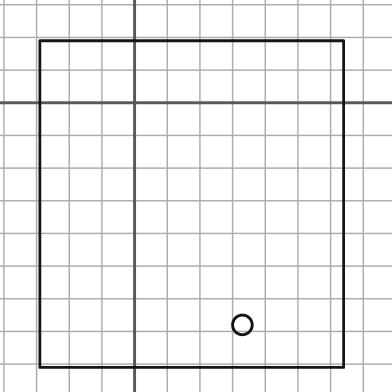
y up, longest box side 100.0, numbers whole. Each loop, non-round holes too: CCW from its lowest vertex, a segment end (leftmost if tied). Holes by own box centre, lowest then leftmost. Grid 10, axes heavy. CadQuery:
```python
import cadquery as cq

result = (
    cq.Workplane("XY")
    .moveTo(-29.0, -81.0)
    .lineTo(64.0, -81.0)
    .lineTo(64.0, 19.0)
    .lineTo(-29.0, 19.0)
    .close()
    .moveTo(33.0, -68.0)
    .circle(3.0)
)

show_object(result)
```